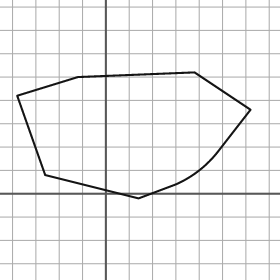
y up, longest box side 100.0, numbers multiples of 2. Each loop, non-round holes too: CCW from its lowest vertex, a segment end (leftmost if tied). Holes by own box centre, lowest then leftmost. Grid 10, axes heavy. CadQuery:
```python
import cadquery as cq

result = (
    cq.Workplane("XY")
    .moveTo(14.0, -2.0)
    .lineTo(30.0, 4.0)
    .threePointArc((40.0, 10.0), (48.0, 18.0))
    .lineTo(62.0, 36.0)
    .lineTo(38.0, 52.0)
    .lineTo(-12.0, 50.0)
    .lineTo(-38.0, 42.0)
    .lineTo(-26.0, 8.0)
    .close()
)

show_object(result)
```